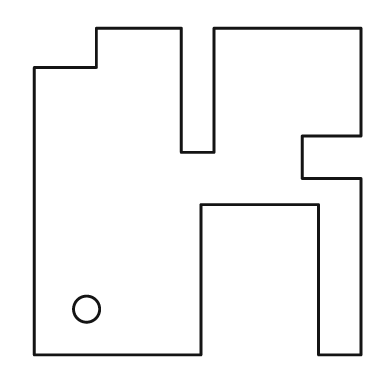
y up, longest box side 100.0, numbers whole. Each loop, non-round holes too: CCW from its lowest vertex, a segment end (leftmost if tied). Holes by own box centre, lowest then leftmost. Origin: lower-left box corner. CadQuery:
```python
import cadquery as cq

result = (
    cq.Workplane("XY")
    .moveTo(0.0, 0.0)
    .lineTo(51.0, 0.0)
    .lineTo(51.0, 46.0)
    .lineTo(87.0, 46.0)
    .lineTo(87.0, 0.0)
    .lineTo(100.0, 0.0)
    .lineTo(100.0, 54.0)
    .lineTo(82.0, 54.0)
    .lineTo(82.0, 67.0)
    .lineTo(100.0, 67.0)
    .lineTo(100.0, 100.0)
    .lineTo(55.0, 100.0)
    .lineTo(55.0, 62.0)
    .lineTo(45.0, 62.0)
    .lineTo(45.0, 100.0)
    .lineTo(19.0, 100.0)
    .lineTo(19.0, 88.0)
    .lineTo(0.0, 88.0)
    .close()
    .moveTo(16.0, 14.0)
    .circle(4.0)
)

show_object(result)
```